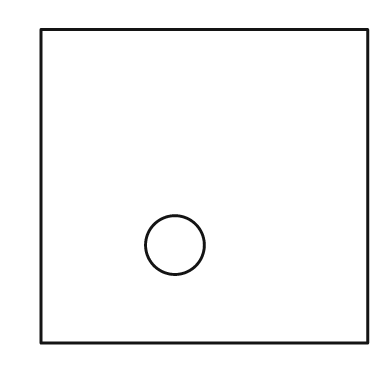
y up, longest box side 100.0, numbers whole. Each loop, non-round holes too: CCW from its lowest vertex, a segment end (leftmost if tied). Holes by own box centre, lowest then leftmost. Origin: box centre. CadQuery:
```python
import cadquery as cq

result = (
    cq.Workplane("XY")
    .moveTo(-50.0, -48.0)
    .lineTo(50.0, -48.0)
    .lineTo(50.0, 48.0)
    .lineTo(-50.0, 48.0)
    .close()
    .moveTo(-9.0, -18.0)
    .circle(9.0)
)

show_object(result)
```